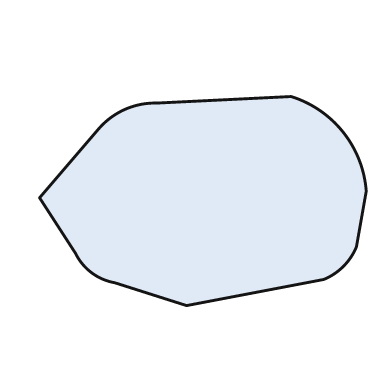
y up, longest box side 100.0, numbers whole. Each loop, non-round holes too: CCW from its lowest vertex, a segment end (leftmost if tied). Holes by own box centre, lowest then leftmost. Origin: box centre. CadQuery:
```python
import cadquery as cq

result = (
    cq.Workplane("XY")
    .moveTo(-5.0, -32.0)
    .lineTo(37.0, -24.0)
    .threePointArc((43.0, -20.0), (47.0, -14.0))
    .lineTo(50.0, 3.0)
    .threePointArc((43.0, 21.0), (27.0, 32.0))
    .lineTo(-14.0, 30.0)
    .threePointArc((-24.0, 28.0), (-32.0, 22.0))
    .lineTo(-50.0, 1.0)
    .lineTo(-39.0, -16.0)
    .threePointArc((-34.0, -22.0), (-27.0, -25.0))
    .close()
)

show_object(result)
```